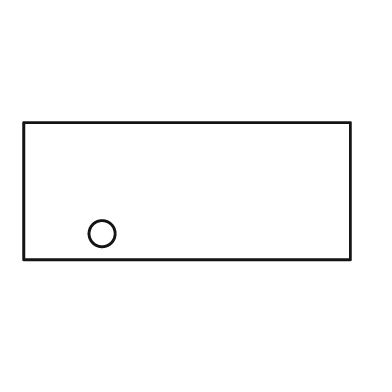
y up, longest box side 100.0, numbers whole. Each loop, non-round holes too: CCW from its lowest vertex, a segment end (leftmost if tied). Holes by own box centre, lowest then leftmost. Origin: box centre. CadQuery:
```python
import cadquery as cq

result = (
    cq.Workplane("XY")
    .moveTo(-50.0, -21.0)
    .lineTo(50.0, -21.0)
    .lineTo(50.0, 21.0)
    .lineTo(-50.0, 21.0)
    .close()
    .moveTo(-26.0, -13.0)
    .circle(4.0)
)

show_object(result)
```